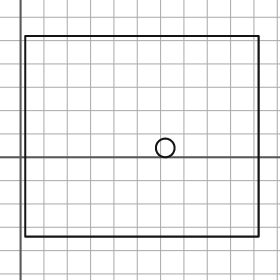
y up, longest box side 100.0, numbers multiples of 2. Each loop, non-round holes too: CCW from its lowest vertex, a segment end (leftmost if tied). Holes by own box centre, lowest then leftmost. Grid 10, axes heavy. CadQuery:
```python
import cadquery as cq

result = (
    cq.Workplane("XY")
    .moveTo(2.0, -34.0)
    .lineTo(102.0, -34.0)
    .lineTo(102.0, 52.0)
    .lineTo(2.0, 52.0)
    .close()
    .moveTo(62.0, 4.0)
    .circle(4.0)
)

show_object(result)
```